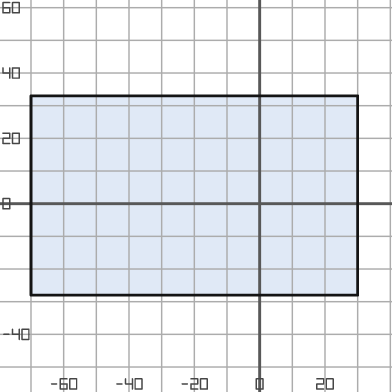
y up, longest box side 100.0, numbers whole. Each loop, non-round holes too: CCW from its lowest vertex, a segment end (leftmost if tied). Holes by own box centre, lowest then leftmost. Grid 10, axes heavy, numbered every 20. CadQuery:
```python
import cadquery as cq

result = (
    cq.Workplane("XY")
    .moveTo(-70.0, -28.0)
    .lineTo(30.0, -28.0)
    .lineTo(30.0, 33.0)
    .lineTo(-70.0, 33.0)
    .close()
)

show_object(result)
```